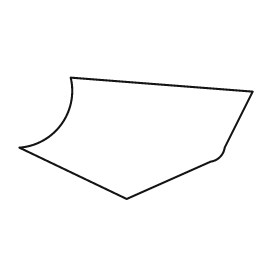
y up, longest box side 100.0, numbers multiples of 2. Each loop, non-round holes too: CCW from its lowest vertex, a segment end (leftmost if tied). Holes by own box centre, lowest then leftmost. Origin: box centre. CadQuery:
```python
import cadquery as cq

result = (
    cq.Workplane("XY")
    .moveTo(-4.0, -26.0)
    .lineTo(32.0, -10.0)
    .threePointArc((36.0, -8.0), (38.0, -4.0))
    .lineTo(50.0, 20.0)
    .lineTo(-28.0, 26.0)
    .threePointArc((-32.0, 6.0), (-50.0, -4.0))
    .close()
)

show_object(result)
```